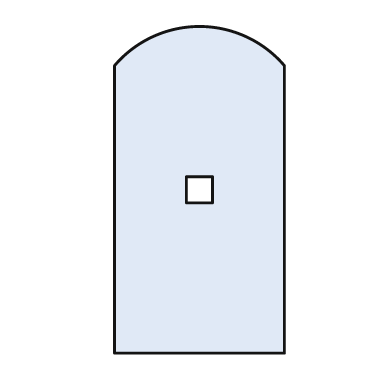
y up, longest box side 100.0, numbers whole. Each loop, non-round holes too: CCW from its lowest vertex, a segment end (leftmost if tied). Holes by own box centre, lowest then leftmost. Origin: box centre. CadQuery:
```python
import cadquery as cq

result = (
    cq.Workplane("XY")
    .moveTo(-26.0, -50.0)
    .lineTo(26.0, -50.0)
    .lineTo(26.0, 38.0)
    .threePointArc((0.0, 50.0), (-26.0, 38.0))
    .close()
    .moveTo(-4.0, -4.0)
    .lineTo(4.0, -4.0)
    .lineTo(4.0, 4.0)
    .lineTo(-4.0, 4.0)
    .close()
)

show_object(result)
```